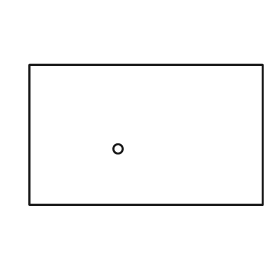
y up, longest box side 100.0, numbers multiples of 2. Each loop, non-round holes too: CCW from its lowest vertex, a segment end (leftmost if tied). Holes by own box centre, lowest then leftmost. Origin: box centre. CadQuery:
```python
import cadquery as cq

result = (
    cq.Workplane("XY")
    .moveTo(-50.0, -30.0)
    .lineTo(50.0, -30.0)
    .lineTo(50.0, 30.0)
    .lineTo(-50.0, 30.0)
    .close()
    .moveTo(-12.0, -6.0)
    .circle(2.0)
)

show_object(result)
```